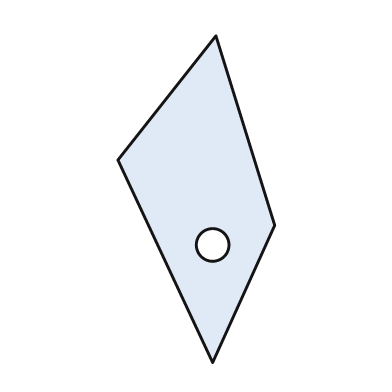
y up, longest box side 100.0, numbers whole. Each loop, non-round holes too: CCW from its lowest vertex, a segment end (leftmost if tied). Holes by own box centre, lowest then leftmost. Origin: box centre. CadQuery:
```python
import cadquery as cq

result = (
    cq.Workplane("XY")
    .moveTo(5.0, -50.0)
    .lineTo(24.0, -8.0)
    .lineTo(6.0, 50.0)
    .lineTo(-24.0, 12.0)
    .close()
    .moveTo(5.0, -14.0)
    .circle(5.0)
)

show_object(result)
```